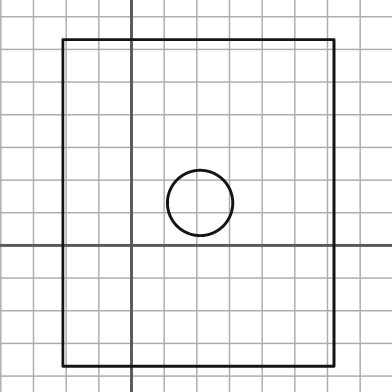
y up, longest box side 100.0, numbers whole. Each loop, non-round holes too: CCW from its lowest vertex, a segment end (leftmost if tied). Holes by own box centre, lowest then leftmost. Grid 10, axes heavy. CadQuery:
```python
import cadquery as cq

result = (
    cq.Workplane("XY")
    .moveTo(-21.0, -37.0)
    .lineTo(62.0, -37.0)
    .lineTo(62.0, 63.0)
    .lineTo(-21.0, 63.0)
    .close()
    .moveTo(21.0, 13.0)
    .circle(10.0)
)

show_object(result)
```